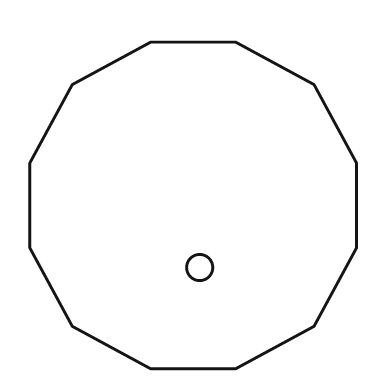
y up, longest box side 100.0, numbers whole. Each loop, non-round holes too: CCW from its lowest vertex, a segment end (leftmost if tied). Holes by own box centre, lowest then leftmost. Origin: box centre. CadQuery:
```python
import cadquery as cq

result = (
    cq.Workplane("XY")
    .moveTo(-13.0, -50.0)
    .lineTo(13.0, -50.0)
    .lineTo(37.0, -37.0)
    .lineTo(50.0, -13.0)
    .lineTo(50.0, 13.0)
    .lineTo(37.0, 37.0)
    .lineTo(13.0, 50.0)
    .lineTo(-13.0, 50.0)
    .lineTo(-37.0, 37.0)
    .lineTo(-50.0, 13.0)
    .lineTo(-50.0, -13.0)
    .lineTo(-37.0, -37.0)
    .close()
    .moveTo(2.0, -19.0)
    .circle(4.0)
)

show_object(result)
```